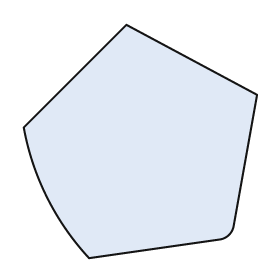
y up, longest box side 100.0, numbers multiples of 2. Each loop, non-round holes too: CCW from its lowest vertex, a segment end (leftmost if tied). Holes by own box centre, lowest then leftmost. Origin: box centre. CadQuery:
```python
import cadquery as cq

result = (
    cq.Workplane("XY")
    .moveTo(-22.0, -50.0)
    .lineTo(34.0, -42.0)
    .threePointArc((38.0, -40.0), (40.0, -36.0))
    .lineTo(50.0, 20.0)
    .lineTo(-6.0, 50.0)
    .lineTo(-50.0, 6.0)
    .threePointArc((-40.0, -24.0), (-22.0, -50.0))
    .close()
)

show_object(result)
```